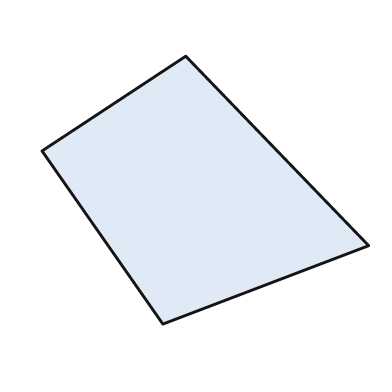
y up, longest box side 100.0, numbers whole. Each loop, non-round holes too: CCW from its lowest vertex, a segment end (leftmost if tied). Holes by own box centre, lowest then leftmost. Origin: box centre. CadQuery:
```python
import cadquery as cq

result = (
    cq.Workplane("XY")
    .moveTo(-13.0, -41.0)
    .lineTo(50.0, -17.0)
    .lineTo(-6.0, 41.0)
    .lineTo(-50.0, 12.0)
    .close()
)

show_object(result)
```